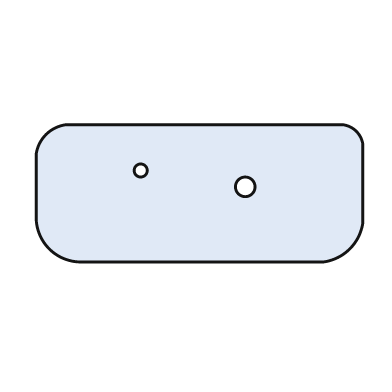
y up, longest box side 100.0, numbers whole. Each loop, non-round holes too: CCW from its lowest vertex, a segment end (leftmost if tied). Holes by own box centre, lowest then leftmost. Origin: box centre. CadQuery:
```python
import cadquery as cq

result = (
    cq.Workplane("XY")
    .moveTo(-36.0, -21.0)
    .lineTo(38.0, -21.0)
    .threePointArc((46.0, -17.0), (50.0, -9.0))
    .lineTo(50.0, 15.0)
    .threePointArc((48.0, 19.0), (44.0, 21.0))
    .lineTo(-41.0, 21.0)
    .threePointArc((-47.0, 18.0), (-50.0, 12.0))
    .lineTo(-50.0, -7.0)
    .threePointArc((-46.0, -17.0), (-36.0, -21.0))
    .close()
    .moveTo(14.0, 2.0)
    .circle(3.0)
    .moveTo(-18.0, 7.0)
    .circle(2.0)
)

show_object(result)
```